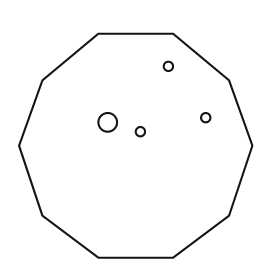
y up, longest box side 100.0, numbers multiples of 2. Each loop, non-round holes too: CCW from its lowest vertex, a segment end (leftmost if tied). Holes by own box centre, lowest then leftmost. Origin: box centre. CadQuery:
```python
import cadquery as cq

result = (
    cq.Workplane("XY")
    .moveTo(-16.0, -48.0)
    .lineTo(16.0, -48.0)
    .lineTo(40.0, -30.0)
    .lineTo(50.0, 0.0)
    .lineTo(40.0, 28.0)
    .lineTo(16.0, 48.0)
    .lineTo(-16.0, 48.0)
    .lineTo(-40.0, 28.0)
    .lineTo(-50.0, 0.0)
    .lineTo(-40.0, -30.0)
    .close()
    .moveTo(2.0, 6.0)
    .circle(2.0)
    .moveTo(-12.0, 10.0)
    .circle(4.0)
    .moveTo(30.0, 12.0)
    .circle(2.0)
    .moveTo(14.0, 34.0)
    .circle(2.0)
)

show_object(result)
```